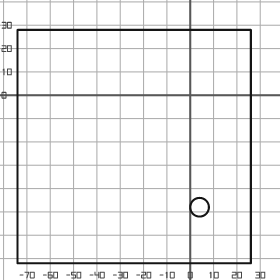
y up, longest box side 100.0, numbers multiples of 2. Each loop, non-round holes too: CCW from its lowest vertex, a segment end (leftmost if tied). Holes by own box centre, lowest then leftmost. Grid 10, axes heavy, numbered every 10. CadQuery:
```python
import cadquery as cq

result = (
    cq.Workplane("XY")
    .moveTo(-74.0, -72.0)
    .lineTo(26.0, -72.0)
    .lineTo(26.0, 28.0)
    .lineTo(-74.0, 28.0)
    .close()
    .moveTo(4.0, -48.0)
    .circle(4.0)
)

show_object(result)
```